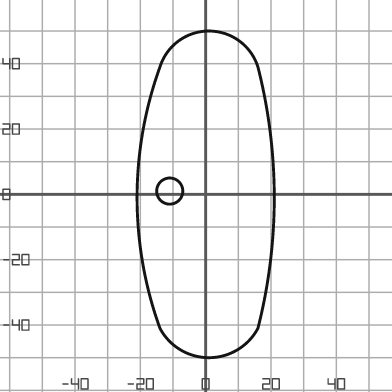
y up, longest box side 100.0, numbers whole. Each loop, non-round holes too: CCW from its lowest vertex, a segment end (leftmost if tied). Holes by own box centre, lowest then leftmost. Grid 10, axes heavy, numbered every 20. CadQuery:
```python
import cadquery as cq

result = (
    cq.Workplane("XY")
    .moveTo(-14.0, -41.0)
    .threePointArc((1.0, -50.0), (16.0, -41.0))
    .threePointArc((21.0, -1.0), (16.0, 39.0))
    .threePointArc((1.0, 50.0), (-14.0, 39.0))
    .threePointArc((-21.0, -1.0), (-14.0, -41.0))
    .close()
    .moveTo(-11.0, 1.0)
    .circle(4.0)
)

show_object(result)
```